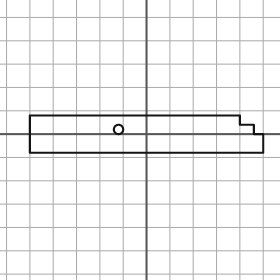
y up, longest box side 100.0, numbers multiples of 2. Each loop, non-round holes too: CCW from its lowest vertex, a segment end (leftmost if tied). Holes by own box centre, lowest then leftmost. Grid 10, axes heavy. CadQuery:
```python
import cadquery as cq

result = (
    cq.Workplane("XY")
    .moveTo(-50.0, -8.0)
    .lineTo(50.0, -8.0)
    .lineTo(50.0, 0.0)
    .lineTo(46.0, 0.0)
    .lineTo(46.0, 4.0)
    .lineTo(40.0, 4.0)
    .lineTo(40.0, 8.0)
    .lineTo(-50.0, 8.0)
    .close()
    .moveTo(-12.0, 2.0)
    .circle(2.0)
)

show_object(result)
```